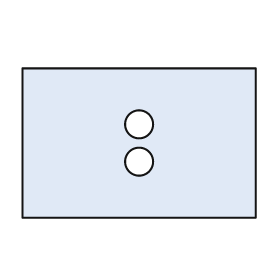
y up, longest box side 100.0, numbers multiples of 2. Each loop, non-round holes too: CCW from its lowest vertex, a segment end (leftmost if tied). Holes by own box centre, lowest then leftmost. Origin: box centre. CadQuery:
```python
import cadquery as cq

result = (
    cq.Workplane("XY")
    .moveTo(-50.0, -32.0)
    .lineTo(50.0, -32.0)
    .lineTo(50.0, 32.0)
    .lineTo(-50.0, 32.0)
    .close()
    .moveTo(0.0, -8.0)
    .circle(6.0)
    .moveTo(0.0, 8.0)
    .circle(6.0)
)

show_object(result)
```